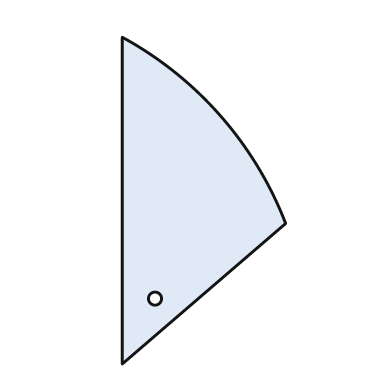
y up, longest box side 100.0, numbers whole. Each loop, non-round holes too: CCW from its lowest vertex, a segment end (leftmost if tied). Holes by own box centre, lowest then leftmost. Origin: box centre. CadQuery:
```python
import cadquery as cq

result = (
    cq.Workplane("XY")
    .moveTo(-25.0, -50.0)
    .lineTo(25.0, -7.0)
    .threePointArc((5.0, 26.0), (-25.0, 50.0))
    .close()
    .moveTo(-15.0, -30.0)
    .circle(2.0)
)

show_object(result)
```